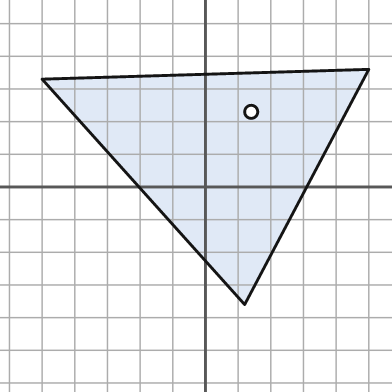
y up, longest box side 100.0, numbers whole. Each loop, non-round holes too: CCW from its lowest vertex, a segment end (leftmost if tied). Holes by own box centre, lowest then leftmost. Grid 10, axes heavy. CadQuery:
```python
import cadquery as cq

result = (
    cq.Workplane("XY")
    .moveTo(12.0, -36.0)
    .lineTo(50.0, 36.0)
    .lineTo(-50.0, 33.0)
    .close()
    .moveTo(14.0, 23.0)
    .circle(2.0)
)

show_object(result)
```